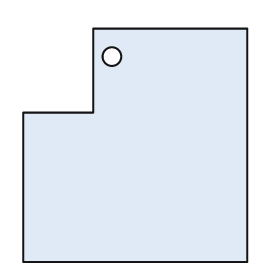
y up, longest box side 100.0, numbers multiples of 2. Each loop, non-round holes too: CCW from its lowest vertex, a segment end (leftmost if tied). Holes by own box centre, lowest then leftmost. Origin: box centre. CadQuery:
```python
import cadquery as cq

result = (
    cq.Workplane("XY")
    .moveTo(-48.0, -50.0)
    .lineTo(48.0, -50.0)
    .lineTo(48.0, 50.0)
    .lineTo(-18.0, 50.0)
    .lineTo(-18.0, 14.0)
    .lineTo(-48.0, 14.0)
    .close()
    .moveTo(-10.0, 38.0)
    .circle(4.0)
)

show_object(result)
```